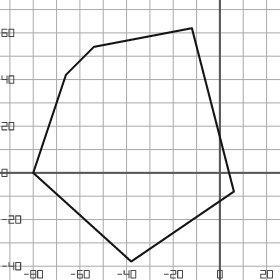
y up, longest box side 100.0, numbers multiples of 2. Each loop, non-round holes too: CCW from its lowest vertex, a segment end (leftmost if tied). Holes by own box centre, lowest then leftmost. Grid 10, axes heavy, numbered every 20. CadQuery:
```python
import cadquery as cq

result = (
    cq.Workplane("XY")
    .moveTo(-38.0, -38.0)
    .lineTo(6.0, -8.0)
    .lineTo(-12.0, 62.0)
    .lineTo(-54.0, 54.0)
    .lineTo(-66.0, 42.0)
    .lineTo(-80.0, 0.0)
    .close()
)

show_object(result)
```